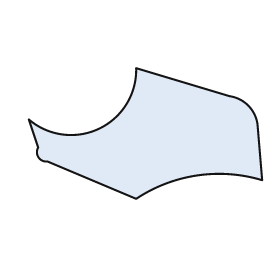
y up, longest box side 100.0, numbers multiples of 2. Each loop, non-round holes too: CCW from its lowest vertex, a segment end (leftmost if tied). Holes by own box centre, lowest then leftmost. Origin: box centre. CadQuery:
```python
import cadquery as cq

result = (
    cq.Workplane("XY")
    .moveTo(-4.0, -28.0)
    .threePointArc((22.0, -18.0), (50.0, -20.0))
    .lineTo(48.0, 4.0)
    .threePointArc((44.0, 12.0), (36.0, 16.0))
    .lineTo(-4.0, 28.0)
    .threePointArc((-20.0, 2.0), (-50.0, 6.0))
    .lineTo(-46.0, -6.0)
    .threePointArc((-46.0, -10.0), (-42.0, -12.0))
    .close()
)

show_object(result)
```